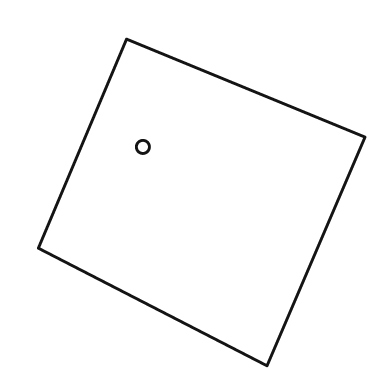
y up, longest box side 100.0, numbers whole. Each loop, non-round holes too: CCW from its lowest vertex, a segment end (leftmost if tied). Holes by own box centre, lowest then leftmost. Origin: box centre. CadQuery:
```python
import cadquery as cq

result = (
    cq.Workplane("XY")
    .moveTo(20.0, -50.0)
    .lineTo(50.0, 20.0)
    .lineTo(-23.0, 50.0)
    .lineTo(-50.0, -14.0)
    .close()
    .moveTo(-18.0, 17.0)
    .circle(2.0)
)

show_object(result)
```